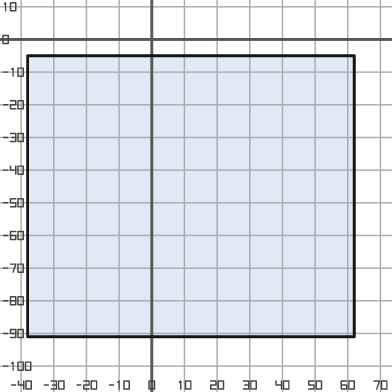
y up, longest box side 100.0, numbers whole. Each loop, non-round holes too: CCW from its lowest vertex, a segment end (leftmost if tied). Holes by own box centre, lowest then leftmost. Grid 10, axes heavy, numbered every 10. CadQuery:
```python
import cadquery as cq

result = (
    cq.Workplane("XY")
    .moveTo(-38.0, -91.0)
    .lineTo(62.0, -91.0)
    .lineTo(62.0, -5.0)
    .lineTo(-38.0, -5.0)
    .close()
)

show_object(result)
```